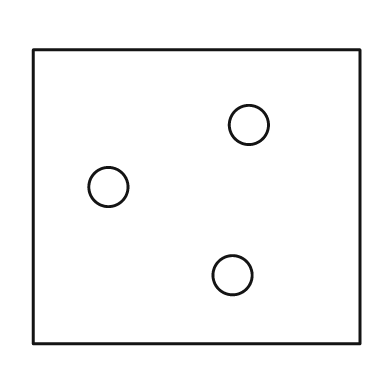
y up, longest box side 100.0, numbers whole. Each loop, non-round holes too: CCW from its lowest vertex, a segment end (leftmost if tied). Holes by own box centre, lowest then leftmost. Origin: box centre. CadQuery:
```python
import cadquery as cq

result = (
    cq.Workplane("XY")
    .moveTo(-50.0, -45.0)
    .lineTo(50.0, -45.0)
    .lineTo(50.0, 45.0)
    .lineTo(-50.0, 45.0)
    .close()
    .moveTo(11.0, -24.0)
    .circle(6.0)
    .moveTo(-27.0, 3.0)
    .circle(6.0)
    .moveTo(16.0, 22.0)
    .circle(6.0)
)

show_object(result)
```